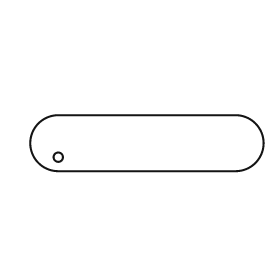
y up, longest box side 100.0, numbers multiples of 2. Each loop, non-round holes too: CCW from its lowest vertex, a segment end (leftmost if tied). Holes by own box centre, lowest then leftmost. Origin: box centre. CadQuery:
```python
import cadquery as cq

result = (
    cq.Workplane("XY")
    .moveTo(-38.0, -12.0)
    .lineTo(38.0, -12.0)
    .threePointArc((50.0, 0.0), (38.0, 12.0))
    .lineTo(-38.0, 12.0)
    .threePointArc((-50.0, 0.0), (-38.0, -12.0))
    .close()
    .moveTo(-38.0, -6.0)
    .circle(2.0)
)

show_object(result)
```